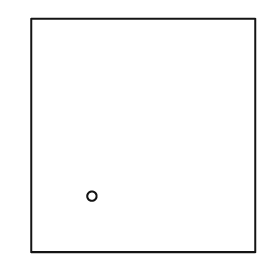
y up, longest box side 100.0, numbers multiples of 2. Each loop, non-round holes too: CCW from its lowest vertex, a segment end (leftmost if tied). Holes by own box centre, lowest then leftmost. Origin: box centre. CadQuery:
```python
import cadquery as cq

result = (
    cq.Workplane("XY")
    .moveTo(-48.0, -50.0)
    .lineTo(48.0, -50.0)
    .lineTo(48.0, 50.0)
    .lineTo(-48.0, 50.0)
    .close()
    .moveTo(-22.0, -26.0)
    .circle(2.0)
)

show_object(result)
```